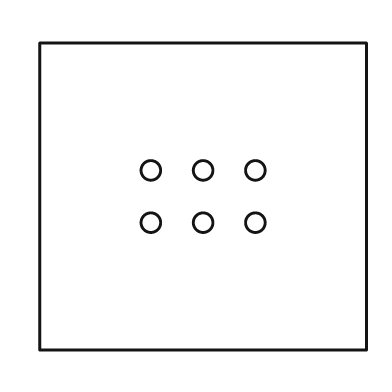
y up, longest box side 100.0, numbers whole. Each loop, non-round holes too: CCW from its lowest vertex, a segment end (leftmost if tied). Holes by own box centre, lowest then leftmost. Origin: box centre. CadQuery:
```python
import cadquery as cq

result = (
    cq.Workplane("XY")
    .moveTo(-50.0, -47.0)
    .lineTo(50.0, -47.0)
    .lineTo(50.0, 47.0)
    .lineTo(-50.0, 47.0)
    .close()
    .moveTo(-16.0, -8.0)
    .circle(3.0)
    .moveTo(0.0, -8.0)
    .circle(3.0)
    .moveTo(16.0, -8.0)
    .circle(3.0)
    .moveTo(-16.0, 8.0)
    .circle(3.0)
    .moveTo(0.0, 8.0)
    .circle(3.0)
    .moveTo(16.0, 8.0)
    .circle(3.0)
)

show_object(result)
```